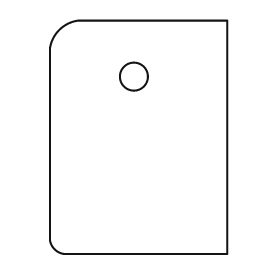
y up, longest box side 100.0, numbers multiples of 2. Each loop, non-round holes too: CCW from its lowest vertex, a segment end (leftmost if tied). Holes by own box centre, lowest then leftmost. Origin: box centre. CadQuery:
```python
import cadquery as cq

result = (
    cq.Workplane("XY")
    .moveTo(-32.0, -50.0)
    .lineTo(38.0, -50.0)
    .lineTo(38.0, 50.0)
    .lineTo(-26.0, 50.0)
    .threePointArc((-34.0, 46.0), (-38.0, 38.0))
    .lineTo(-38.0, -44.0)
    .threePointArc((-36.0, -48.0), (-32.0, -50.0))
    .close()
    .moveTo(-2.0, 26.0)
    .circle(6.0)
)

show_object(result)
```